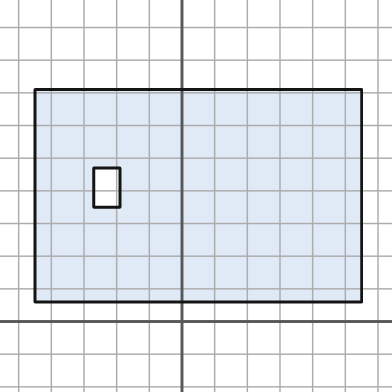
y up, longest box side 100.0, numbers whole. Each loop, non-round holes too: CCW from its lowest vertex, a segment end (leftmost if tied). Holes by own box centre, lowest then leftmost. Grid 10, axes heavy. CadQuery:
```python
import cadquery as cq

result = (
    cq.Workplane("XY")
    .moveTo(-45.0, 6.0)
    .lineTo(55.0, 6.0)
    .lineTo(55.0, 71.0)
    .lineTo(-45.0, 71.0)
    .close()
    .moveTo(-27.0, 35.0)
    .lineTo(-19.0, 35.0)
    .lineTo(-19.0, 47.0)
    .lineTo(-27.0, 47.0)
    .close()
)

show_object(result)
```